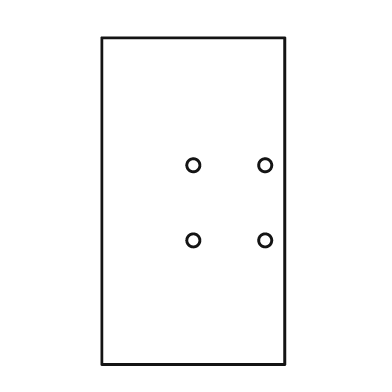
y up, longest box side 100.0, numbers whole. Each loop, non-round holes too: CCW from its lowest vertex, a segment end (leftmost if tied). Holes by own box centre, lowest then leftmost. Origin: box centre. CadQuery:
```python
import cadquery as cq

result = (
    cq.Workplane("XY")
    .moveTo(-28.0, -50.0)
    .lineTo(28.0, -50.0)
    .lineTo(28.0, 50.0)
    .lineTo(-28.0, 50.0)
    .close()
    .moveTo(0.0, -12.0)
    .circle(2.0)
    .moveTo(22.0, -12.0)
    .circle(2.0)
    .moveTo(0.0, 11.0)
    .circle(2.0)
    .moveTo(22.0, 11.0)
    .circle(2.0)
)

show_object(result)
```